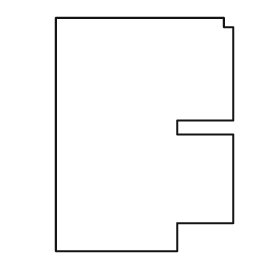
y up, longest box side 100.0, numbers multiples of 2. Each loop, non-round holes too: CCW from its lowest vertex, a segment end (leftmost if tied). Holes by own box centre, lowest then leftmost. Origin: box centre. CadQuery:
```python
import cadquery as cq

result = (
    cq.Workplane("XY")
    .moveTo(-38.0, -50.0)
    .lineTo(14.0, -50.0)
    .lineTo(14.0, -38.0)
    .lineTo(38.0, -38.0)
    .lineTo(38.0, 0.0)
    .lineTo(14.0, 0.0)
    .lineTo(14.0, 6.0)
    .lineTo(38.0, 6.0)
    .lineTo(38.0, 46.0)
    .lineTo(34.0, 46.0)
    .lineTo(34.0, 50.0)
    .lineTo(-38.0, 50.0)
    .close()
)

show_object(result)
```